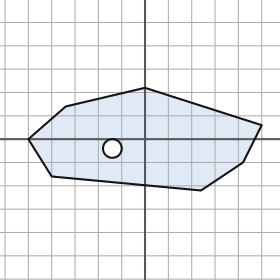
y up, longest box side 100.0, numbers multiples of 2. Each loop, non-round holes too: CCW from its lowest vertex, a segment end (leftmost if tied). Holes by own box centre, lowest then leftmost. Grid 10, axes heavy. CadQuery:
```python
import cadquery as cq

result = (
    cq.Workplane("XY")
    .moveTo(24.0, -22.0)
    .lineTo(42.0, -10.0)
    .lineTo(50.0, 6.0)
    .lineTo(0.0, 22.0)
    .lineTo(-34.0, 14.0)
    .lineTo(-50.0, 0.0)
    .lineTo(-40.0, -16.0)
    .close()
    .moveTo(-14.0, -4.0)
    .circle(4.0)
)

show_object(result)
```